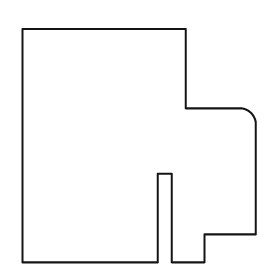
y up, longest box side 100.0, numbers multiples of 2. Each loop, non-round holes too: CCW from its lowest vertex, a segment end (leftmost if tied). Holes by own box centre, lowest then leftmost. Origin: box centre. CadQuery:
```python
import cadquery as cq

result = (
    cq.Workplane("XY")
    .moveTo(-50.0, -50.0)
    .lineTo(8.0, -50.0)
    .lineTo(8.0, -12.0)
    .lineTo(14.0, -12.0)
    .lineTo(14.0, -50.0)
    .lineTo(28.0, -50.0)
    .lineTo(28.0, -38.0)
    .lineTo(50.0, -38.0)
    .lineTo(50.0, 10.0)
    .threePointArc((48.0, 14.0), (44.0, 16.0))
    .lineTo(20.0, 16.0)
    .lineTo(20.0, 50.0)
    .lineTo(-50.0, 50.0)
    .close()
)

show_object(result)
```